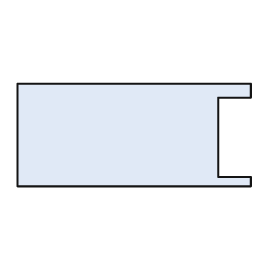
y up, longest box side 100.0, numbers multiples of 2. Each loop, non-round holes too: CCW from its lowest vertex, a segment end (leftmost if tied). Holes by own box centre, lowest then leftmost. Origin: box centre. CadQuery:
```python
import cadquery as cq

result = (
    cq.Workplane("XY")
    .moveTo(-50.0, -22.0)
    .lineTo(50.0, -22.0)
    .lineTo(50.0, -18.0)
    .lineTo(36.0, -18.0)
    .lineTo(36.0, 16.0)
    .lineTo(50.0, 16.0)
    .lineTo(50.0, 22.0)
    .lineTo(-50.0, 22.0)
    .close()
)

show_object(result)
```